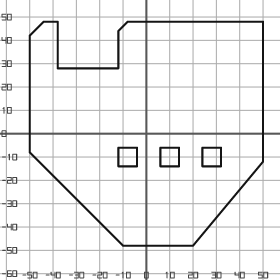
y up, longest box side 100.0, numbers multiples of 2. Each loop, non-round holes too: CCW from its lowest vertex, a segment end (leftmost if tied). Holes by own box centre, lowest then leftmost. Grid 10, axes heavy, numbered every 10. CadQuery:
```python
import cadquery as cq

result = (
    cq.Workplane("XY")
    .moveTo(-10.0, -48.0)
    .lineTo(20.0, -48.0)
    .lineTo(50.0, -12.0)
    .lineTo(50.0, 48.0)
    .lineTo(-8.0, 48.0)
    .lineTo(-12.0, 44.0)
    .lineTo(-12.0, 28.0)
    .lineTo(-38.0, 28.0)
    .lineTo(-38.0, 48.0)
    .lineTo(-44.0, 48.0)
    .lineTo(-50.0, 42.0)
    .lineTo(-50.0, -8.0)
    .close()
    .moveTo(-12.0, -14.0)
    .lineTo(-4.0, -14.0)
    .lineTo(-4.0, -6.0)
    .lineTo(-12.0, -6.0)
    .close()
    .moveTo(6.0, -14.0)
    .lineTo(14.0, -14.0)
    .lineTo(14.0, -6.0)
    .lineTo(6.0, -6.0)
    .close()
    .moveTo(24.0, -14.0)
    .lineTo(32.0, -14.0)
    .lineTo(32.0, -6.0)
    .lineTo(24.0, -6.0)
    .close()
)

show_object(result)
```